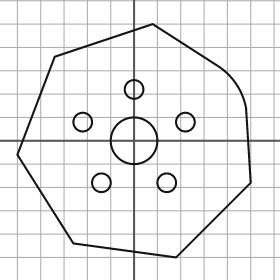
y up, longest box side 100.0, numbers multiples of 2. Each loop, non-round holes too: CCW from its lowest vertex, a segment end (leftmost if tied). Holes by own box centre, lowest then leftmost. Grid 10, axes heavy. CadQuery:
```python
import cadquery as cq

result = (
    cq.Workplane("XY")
    .moveTo(18.0, -50.0)
    .lineTo(50.0, -18.0)
    .lineTo(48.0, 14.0)
    .threePointArc((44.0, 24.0), (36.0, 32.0))
    .lineTo(8.0, 50.0)
    .lineTo(-34.0, 36.0)
    .lineTo(-50.0, -6.0)
    .lineTo(-26.0, -44.0)
    .close()
    .moveTo(-14.0, -18.0)
    .circle(4.0)
    .moveTo(14.0, -18.0)
    .circle(4.0)
    .moveTo(0.0, 0.0)
    .circle(10.0)
    .moveTo(-22.0, 8.0)
    .circle(4.0)
    .moveTo(22.0, 8.0)
    .circle(4.0)
    .moveTo(0.0, 22.0)
    .circle(4.0)
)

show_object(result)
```